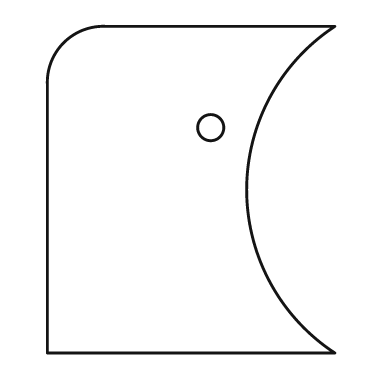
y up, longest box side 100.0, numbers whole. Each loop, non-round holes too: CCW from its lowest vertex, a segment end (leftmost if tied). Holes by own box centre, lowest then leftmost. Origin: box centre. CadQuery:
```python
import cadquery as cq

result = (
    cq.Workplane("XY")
    .moveTo(-44.0, -50.0)
    .lineTo(44.0, -50.0)
    .threePointArc((17.0, 0.0), (44.0, 50.0))
    .lineTo(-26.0, 50.0)
    .threePointArc((-39.0, 45.0), (-44.0, 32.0))
    .close()
    .moveTo(6.0, 19.0)
    .circle(4.0)
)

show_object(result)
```